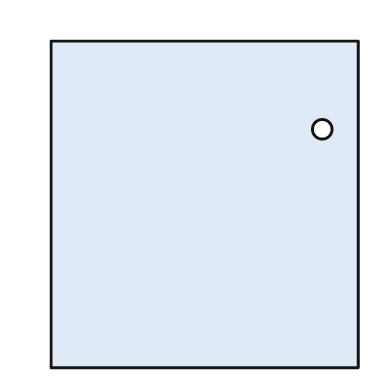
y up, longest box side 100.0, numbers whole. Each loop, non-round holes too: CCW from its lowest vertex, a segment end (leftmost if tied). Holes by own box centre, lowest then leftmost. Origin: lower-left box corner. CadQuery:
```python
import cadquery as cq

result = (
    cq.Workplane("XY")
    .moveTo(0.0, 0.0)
    .lineTo(94.0, 0.0)
    .lineTo(94.0, 100.0)
    .lineTo(0.0, 100.0)
    .close()
    .moveTo(83.0, 73.0)
    .circle(3.0)
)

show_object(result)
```